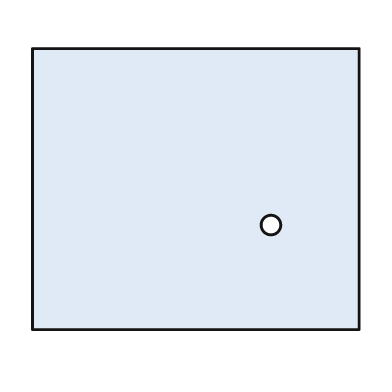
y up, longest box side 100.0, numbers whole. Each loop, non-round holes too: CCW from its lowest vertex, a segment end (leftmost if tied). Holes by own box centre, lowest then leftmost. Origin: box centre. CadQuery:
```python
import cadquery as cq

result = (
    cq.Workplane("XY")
    .moveTo(-50.0, -43.0)
    .lineTo(50.0, -43.0)
    .lineTo(50.0, 43.0)
    .lineTo(-50.0, 43.0)
    .close()
    .moveTo(23.0, -11.0)
    .circle(3.0)
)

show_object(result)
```